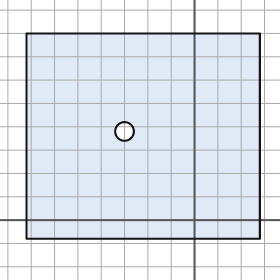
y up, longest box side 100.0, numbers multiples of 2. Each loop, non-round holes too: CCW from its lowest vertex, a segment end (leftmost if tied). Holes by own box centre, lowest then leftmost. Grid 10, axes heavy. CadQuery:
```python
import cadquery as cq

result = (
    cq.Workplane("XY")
    .moveTo(-72.0, -8.0)
    .lineTo(28.0, -8.0)
    .lineTo(28.0, 80.0)
    .lineTo(-72.0, 80.0)
    .close()
    .moveTo(-30.0, 38.0)
    .circle(4.0)
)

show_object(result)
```